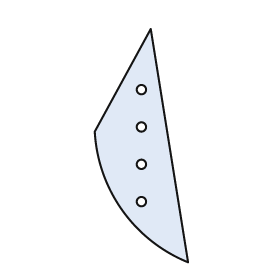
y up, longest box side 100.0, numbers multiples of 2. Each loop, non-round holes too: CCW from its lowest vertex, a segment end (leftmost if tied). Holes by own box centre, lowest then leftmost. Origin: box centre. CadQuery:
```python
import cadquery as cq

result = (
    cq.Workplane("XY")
    .moveTo(20.0, -50.0)
    .lineTo(4.0, 50.0)
    .lineTo(-20.0, 6.0)
    .threePointArc((-8.0, -28.0), (20.0, -50.0))
    .close()
    .moveTo(0.0, -24.0)
    .circle(2.0)
    .moveTo(0.0, -8.0)
    .circle(2.0)
    .moveTo(0.0, 8.0)
    .circle(2.0)
    .moveTo(0.0, 24.0)
    .circle(2.0)
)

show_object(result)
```